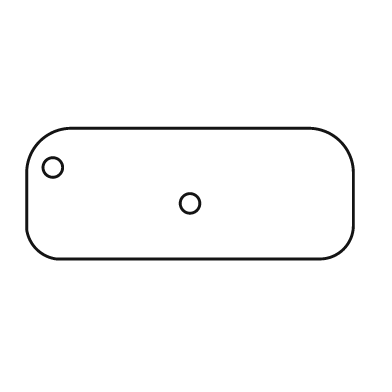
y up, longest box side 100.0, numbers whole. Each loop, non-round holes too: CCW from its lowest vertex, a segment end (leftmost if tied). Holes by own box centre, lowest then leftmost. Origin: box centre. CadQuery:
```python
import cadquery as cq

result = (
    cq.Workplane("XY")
    .moveTo(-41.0, -20.0)
    .lineTo(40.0, -20.0)
    .threePointArc((47.0, -17.0), (50.0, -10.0))
    .lineTo(50.0, 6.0)
    .threePointArc((46.0, 16.0), (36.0, 20.0))
    .lineTo(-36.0, 20.0)
    .threePointArc((-46.0, 16.0), (-50.0, 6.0))
    .lineTo(-50.0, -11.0)
    .threePointArc((-47.0, -17.0), (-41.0, -20.0))
    .close()
    .moveTo(0.0, -3.0)
    .circle(3.0)
    .moveTo(-42.0, 8.0)
    .circle(3.0)
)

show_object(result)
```